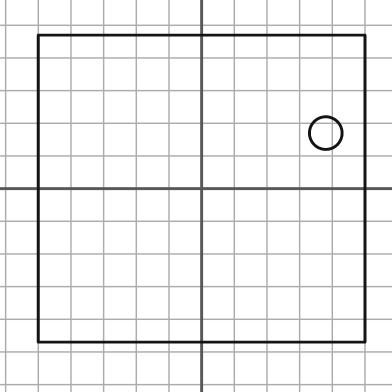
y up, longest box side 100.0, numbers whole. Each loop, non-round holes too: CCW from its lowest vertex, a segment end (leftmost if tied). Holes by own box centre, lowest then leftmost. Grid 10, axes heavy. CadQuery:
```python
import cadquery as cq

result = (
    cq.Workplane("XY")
    .moveTo(-50.0, -47.0)
    .lineTo(50.0, -47.0)
    .lineTo(50.0, 47.0)
    .lineTo(-50.0, 47.0)
    .close()
    .moveTo(38.0, 17.0)
    .circle(5.0)
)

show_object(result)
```